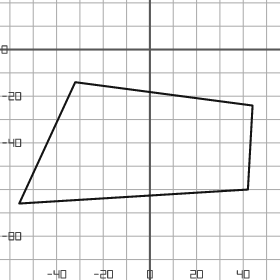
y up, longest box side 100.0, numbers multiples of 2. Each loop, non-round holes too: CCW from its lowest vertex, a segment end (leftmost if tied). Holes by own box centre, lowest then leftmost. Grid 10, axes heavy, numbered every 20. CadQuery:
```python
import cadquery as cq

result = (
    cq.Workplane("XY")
    .moveTo(-56.0, -66.0)
    .lineTo(42.0, -60.0)
    .lineTo(44.0, -24.0)
    .lineTo(-32.0, -14.0)
    .close()
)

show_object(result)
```